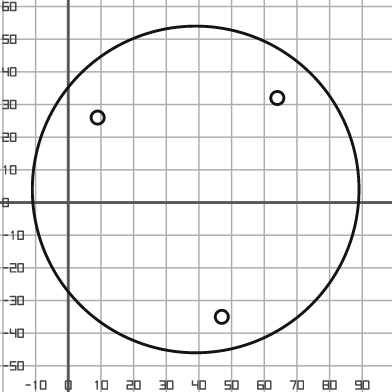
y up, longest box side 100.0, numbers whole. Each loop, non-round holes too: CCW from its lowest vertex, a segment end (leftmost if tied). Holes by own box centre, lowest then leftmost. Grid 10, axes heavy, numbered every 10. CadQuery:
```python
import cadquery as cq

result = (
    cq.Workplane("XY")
    .moveTo(39.0, 4.0)
    .circle(50.0)
    .moveTo(47.0, -35.0)
    .circle(2.0)
    .moveTo(9.0, 26.0)
    .circle(2.0)
    .moveTo(64.0, 32.0)
    .circle(2.0)
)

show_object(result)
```